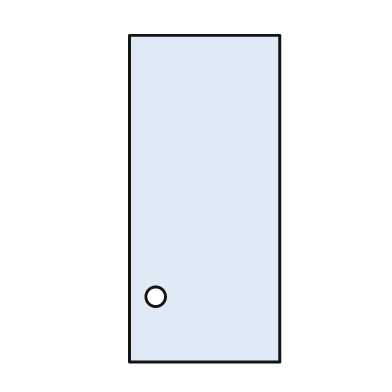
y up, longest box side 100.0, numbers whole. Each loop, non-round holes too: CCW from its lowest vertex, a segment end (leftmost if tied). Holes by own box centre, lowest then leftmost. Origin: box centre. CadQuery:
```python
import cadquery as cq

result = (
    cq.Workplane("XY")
    .moveTo(-23.0, -50.0)
    .lineTo(23.0, -50.0)
    .lineTo(23.0, 50.0)
    .lineTo(-23.0, 50.0)
    .close()
    .moveTo(-15.0, -30.0)
    .circle(3.0)
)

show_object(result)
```